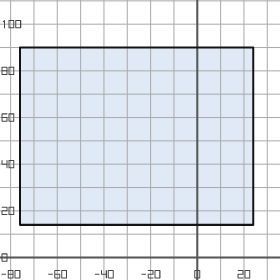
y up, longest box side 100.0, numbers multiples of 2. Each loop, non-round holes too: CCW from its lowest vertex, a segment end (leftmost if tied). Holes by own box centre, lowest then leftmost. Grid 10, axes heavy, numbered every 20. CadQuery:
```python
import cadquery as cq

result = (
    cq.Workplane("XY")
    .moveTo(-76.0, 14.0)
    .lineTo(24.0, 14.0)
    .lineTo(24.0, 90.0)
    .lineTo(-76.0, 90.0)
    .close()
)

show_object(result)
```